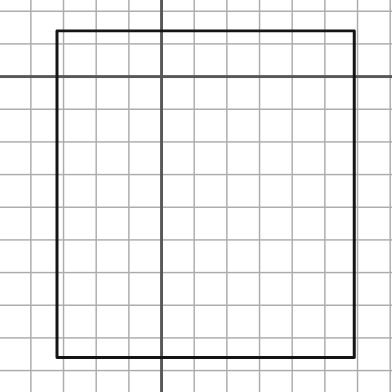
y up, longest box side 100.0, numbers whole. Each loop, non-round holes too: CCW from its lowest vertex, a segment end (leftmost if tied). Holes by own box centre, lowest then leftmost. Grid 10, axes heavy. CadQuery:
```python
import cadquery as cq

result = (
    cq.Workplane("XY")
    .moveTo(-32.0, -86.0)
    .lineTo(59.0, -86.0)
    .lineTo(59.0, 14.0)
    .lineTo(-32.0, 14.0)
    .close()
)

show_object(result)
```